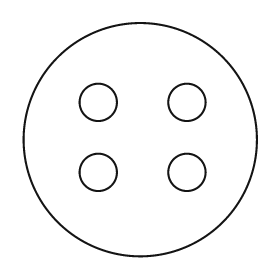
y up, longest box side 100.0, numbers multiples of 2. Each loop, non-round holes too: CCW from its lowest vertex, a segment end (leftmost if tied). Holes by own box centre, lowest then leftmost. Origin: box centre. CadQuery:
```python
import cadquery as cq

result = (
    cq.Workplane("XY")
    .moveTo(0.0, 0.0)
    .circle(50.0)
    .moveTo(-18.0, -14.0)
    .circle(8.0)
    .moveTo(20.0, -14.0)
    .circle(8.0)
    .moveTo(-18.0, 16.0)
    .circle(8.0)
    .moveTo(20.0, 16.0)
    .circle(8.0)
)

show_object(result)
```